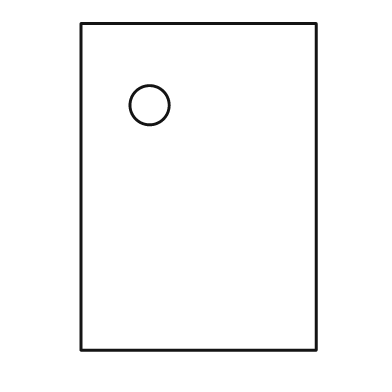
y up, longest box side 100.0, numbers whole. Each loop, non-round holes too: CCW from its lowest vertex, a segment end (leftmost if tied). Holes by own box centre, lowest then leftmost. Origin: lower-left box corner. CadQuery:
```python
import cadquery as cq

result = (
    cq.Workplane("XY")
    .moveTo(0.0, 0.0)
    .lineTo(72.0, 0.0)
    .lineTo(72.0, 100.0)
    .lineTo(0.0, 100.0)
    .close()
    .moveTo(21.0, 75.0)
    .circle(6.0)
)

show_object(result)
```